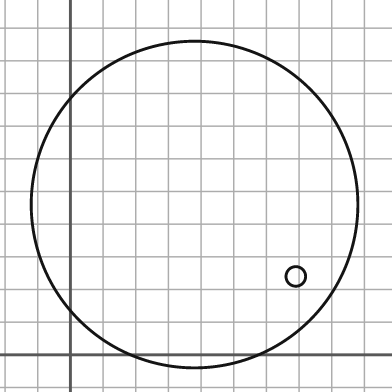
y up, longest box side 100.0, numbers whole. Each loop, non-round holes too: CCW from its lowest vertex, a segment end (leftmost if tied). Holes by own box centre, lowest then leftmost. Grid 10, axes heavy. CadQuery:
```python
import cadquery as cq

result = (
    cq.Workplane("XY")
    .moveTo(38.0, 46.0)
    .circle(50.0)
    .moveTo(69.0, 24.0)
    .circle(3.0)
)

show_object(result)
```